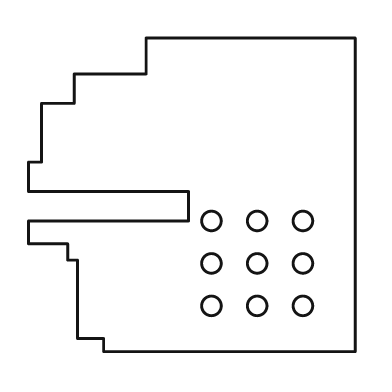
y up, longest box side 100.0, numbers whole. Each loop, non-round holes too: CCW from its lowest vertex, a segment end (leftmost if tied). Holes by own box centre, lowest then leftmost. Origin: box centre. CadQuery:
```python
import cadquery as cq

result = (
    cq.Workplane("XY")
    .moveTo(-27.0, -48.0)
    .lineTo(50.0, -48.0)
    .lineTo(50.0, 48.0)
    .lineTo(-14.0, 48.0)
    .lineTo(-14.0, 37.0)
    .lineTo(-36.0, 37.0)
    .lineTo(-36.0, 28.0)
    .lineTo(-46.0, 28.0)
    .lineTo(-46.0, 10.0)
    .lineTo(-50.0, 10.0)
    .lineTo(-50.0, 1.0)
    .lineTo(-1.0, 1.0)
    .lineTo(-1.0, -8.0)
    .lineTo(-50.0, -8.0)
    .lineTo(-50.0, -15.0)
    .lineTo(-38.0, -15.0)
    .lineTo(-38.0, -20.0)
    .lineTo(-35.0, -20.0)
    .lineTo(-35.0, -44.0)
    .lineTo(-27.0, -44.0)
    .close()
    .moveTo(6.0, -34.0)
    .circle(3.0)
    .moveTo(20.0, -34.0)
    .circle(3.0)
    .moveTo(34.0, -34.0)
    .circle(3.0)
    .moveTo(6.0, -21.0)
    .circle(3.0)
    .moveTo(20.0, -21.0)
    .circle(3.0)
    .moveTo(34.0, -21.0)
    .circle(3.0)
    .moveTo(6.0, -8.0)
    .circle(3.0)
    .moveTo(20.0, -8.0)
    .circle(3.0)
    .moveTo(34.0, -8.0)
    .circle(3.0)
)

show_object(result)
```